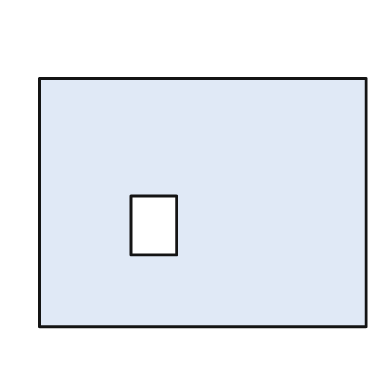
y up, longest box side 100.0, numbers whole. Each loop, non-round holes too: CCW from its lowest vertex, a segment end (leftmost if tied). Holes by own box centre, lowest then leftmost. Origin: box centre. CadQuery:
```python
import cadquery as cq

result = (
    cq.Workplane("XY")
    .moveTo(-50.0, -38.0)
    .lineTo(50.0, -38.0)
    .lineTo(50.0, 38.0)
    .lineTo(-50.0, 38.0)
    .close()
    .moveTo(-22.0, -16.0)
    .lineTo(-8.0, -16.0)
    .lineTo(-8.0, 2.0)
    .lineTo(-22.0, 2.0)
    .close()
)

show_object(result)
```